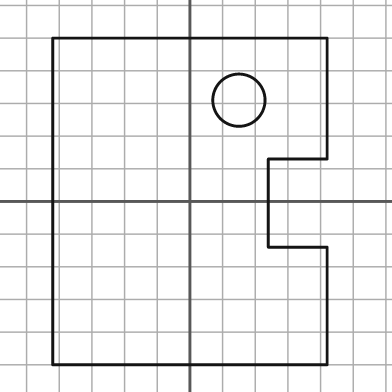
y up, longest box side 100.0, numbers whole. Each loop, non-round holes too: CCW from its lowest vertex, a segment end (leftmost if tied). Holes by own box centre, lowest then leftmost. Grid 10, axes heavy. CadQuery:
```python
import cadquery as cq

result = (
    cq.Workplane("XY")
    .moveTo(-42.0, -50.0)
    .lineTo(42.0, -50.0)
    .lineTo(42.0, -14.0)
    .lineTo(24.0, -14.0)
    .lineTo(24.0, 13.0)
    .lineTo(42.0, 13.0)
    .lineTo(42.0, 50.0)
    .lineTo(-42.0, 50.0)
    .close()
    .moveTo(15.0, 31.0)
    .circle(8.0)
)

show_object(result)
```